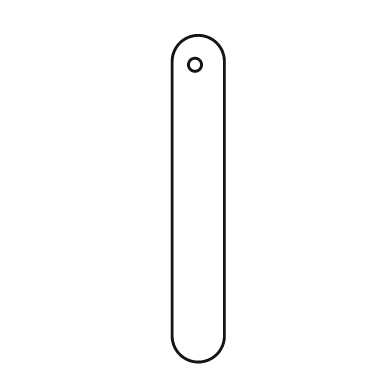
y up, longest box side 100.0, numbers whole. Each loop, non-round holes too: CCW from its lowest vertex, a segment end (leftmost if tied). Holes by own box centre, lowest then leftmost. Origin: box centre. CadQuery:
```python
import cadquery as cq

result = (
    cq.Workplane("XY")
    .moveTo(-8.0, -42.0)
    .threePointArc((0.0, -50.0), (8.0, -42.0))
    .lineTo(8.0, 42.0)
    .threePointArc((0.0, 50.0), (-8.0, 42.0))
    .close()
    .moveTo(-1.0, 41.0)
    .circle(2.0)
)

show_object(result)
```